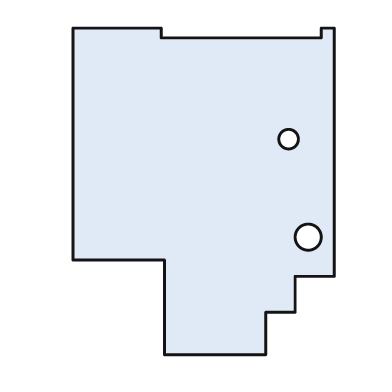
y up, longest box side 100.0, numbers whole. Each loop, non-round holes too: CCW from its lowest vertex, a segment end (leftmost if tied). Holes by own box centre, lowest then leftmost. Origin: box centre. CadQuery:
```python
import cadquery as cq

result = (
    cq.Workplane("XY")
    .moveTo(-12.0, -50.0)
    .lineTo(19.0, -50.0)
    .lineTo(19.0, -37.0)
    .lineTo(28.0, -37.0)
    .lineTo(28.0, -26.0)
    .lineTo(40.0, -26.0)
    .lineTo(40.0, 50.0)
    .lineTo(36.0, 50.0)
    .lineTo(36.0, 47.0)
    .lineTo(-13.0, 47.0)
    .lineTo(-13.0, 50.0)
    .lineTo(-40.0, 50.0)
    .lineTo(-40.0, -21.0)
    .lineTo(-12.0, -21.0)
    .close()
    .moveTo(32.0, -14.0)
    .circle(4.0)
    .moveTo(26.0, 16.0)
    .circle(3.0)
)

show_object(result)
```